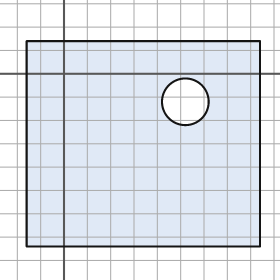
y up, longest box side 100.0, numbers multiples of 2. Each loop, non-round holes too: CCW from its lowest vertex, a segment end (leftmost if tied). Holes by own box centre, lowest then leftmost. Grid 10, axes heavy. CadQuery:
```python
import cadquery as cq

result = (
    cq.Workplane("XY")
    .moveTo(-16.0, -74.0)
    .lineTo(84.0, -74.0)
    .lineTo(84.0, 14.0)
    .lineTo(-16.0, 14.0)
    .close()
    .moveTo(52.0, -12.0)
    .circle(10.0)
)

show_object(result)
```